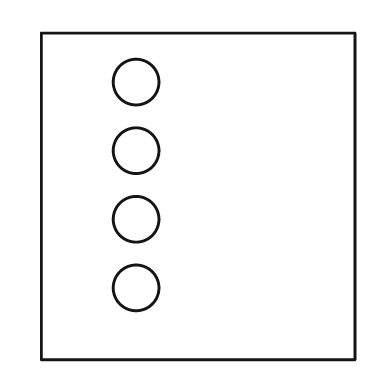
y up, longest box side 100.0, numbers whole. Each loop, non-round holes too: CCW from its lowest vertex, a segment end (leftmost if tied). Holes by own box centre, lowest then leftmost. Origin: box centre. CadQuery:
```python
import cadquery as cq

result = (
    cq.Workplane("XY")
    .moveTo(-48.0, -50.0)
    .lineTo(48.0, -50.0)
    .lineTo(48.0, 50.0)
    .lineTo(-48.0, 50.0)
    .close()
    .moveTo(-19.0, -28.0)
    .circle(7.0)
    .moveTo(-19.0, -7.0)
    .circle(7.0)
    .moveTo(-19.0, 14.0)
    .circle(7.0)
    .moveTo(-19.0, 35.0)
    .circle(7.0)
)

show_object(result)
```